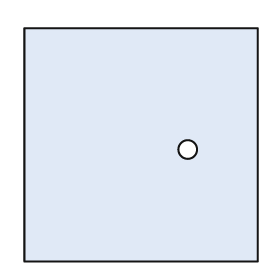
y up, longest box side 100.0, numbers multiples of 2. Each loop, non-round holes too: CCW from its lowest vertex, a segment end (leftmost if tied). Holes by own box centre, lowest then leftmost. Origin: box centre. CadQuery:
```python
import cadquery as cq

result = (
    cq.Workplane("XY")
    .moveTo(-50.0, -50.0)
    .lineTo(50.0, -50.0)
    .lineTo(50.0, 50.0)
    .lineTo(-50.0, 50.0)
    .close()
    .moveTo(20.0, -2.0)
    .circle(4.0)
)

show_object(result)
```